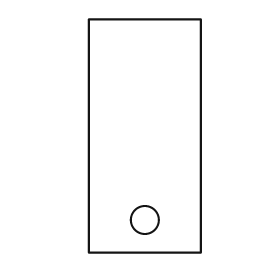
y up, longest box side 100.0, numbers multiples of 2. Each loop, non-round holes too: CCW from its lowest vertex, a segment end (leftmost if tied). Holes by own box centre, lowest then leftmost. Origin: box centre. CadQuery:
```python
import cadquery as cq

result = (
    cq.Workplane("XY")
    .moveTo(-24.0, -50.0)
    .lineTo(24.0, -50.0)
    .lineTo(24.0, 50.0)
    .lineTo(-24.0, 50.0)
    .close()
    .moveTo(0.0, -36.0)
    .circle(6.0)
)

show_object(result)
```